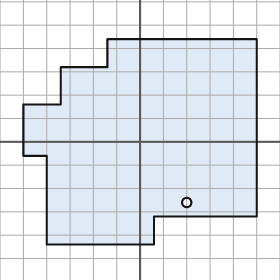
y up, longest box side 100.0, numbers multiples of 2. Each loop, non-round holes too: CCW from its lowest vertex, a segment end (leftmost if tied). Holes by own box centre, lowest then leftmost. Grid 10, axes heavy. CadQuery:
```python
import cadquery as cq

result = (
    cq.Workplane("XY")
    .moveTo(-40.0, -44.0)
    .lineTo(6.0, -44.0)
    .lineTo(6.0, -32.0)
    .lineTo(50.0, -32.0)
    .lineTo(50.0, 44.0)
    .lineTo(-14.0, 44.0)
    .lineTo(-14.0, 32.0)
    .lineTo(-34.0, 32.0)
    .lineTo(-34.0, 16.0)
    .lineTo(-50.0, 16.0)
    .lineTo(-50.0, -6.0)
    .lineTo(-40.0, -6.0)
    .close()
    .moveTo(20.0, -26.0)
    .circle(2.0)
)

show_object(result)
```